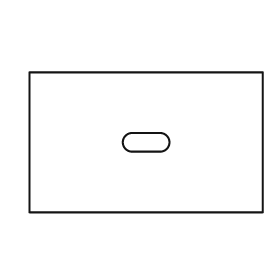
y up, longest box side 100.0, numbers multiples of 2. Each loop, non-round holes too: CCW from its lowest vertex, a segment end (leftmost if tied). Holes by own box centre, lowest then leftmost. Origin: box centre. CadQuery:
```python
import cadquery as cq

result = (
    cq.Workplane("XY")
    .moveTo(-50.0, -30.0)
    .lineTo(50.0, -30.0)
    .lineTo(50.0, 30.0)
    .lineTo(-50.0, 30.0)
    .close()
    .moveTo(-6.0, -4.0)
    .lineTo(6.0, -4.0)
    .threePointArc((10.0, 0.0), (6.0, 4.0))
    .lineTo(-6.0, 4.0)
    .threePointArc((-10.0, 0.0), (-6.0, -4.0))
    .close()
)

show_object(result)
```